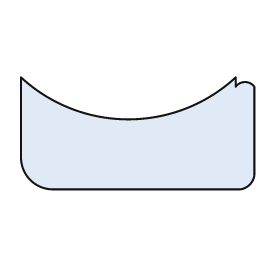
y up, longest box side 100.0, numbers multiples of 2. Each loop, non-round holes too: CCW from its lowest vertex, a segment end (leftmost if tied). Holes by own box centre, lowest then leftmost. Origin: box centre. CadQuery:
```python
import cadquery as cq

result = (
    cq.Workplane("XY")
    .moveTo(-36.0, -24.0)
    .lineTo(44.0, -24.0)
    .threePointArc((48.0, -22.0), (50.0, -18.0))
    .lineTo(50.0, 20.0)
    .threePointArc((46.0, 22.0), (42.0, 20.0))
    .lineTo(42.0, 24.0)
    .threePointArc((-4.0, 6.0), (-50.0, 24.0))
    .lineTo(-50.0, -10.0)
    .threePointArc((-46.0, -20.0), (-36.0, -24.0))
    .close()
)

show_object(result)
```